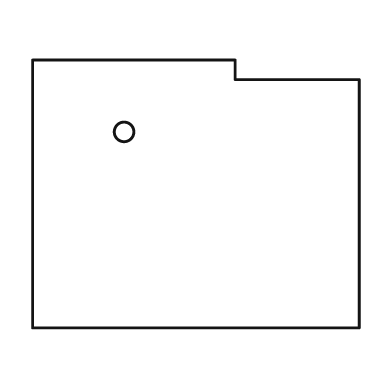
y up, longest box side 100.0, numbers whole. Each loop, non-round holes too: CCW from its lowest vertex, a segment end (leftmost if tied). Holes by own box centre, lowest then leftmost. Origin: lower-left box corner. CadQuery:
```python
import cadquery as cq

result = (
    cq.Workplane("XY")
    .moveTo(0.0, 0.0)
    .lineTo(100.0, 0.0)
    .lineTo(100.0, 76.0)
    .lineTo(62.0, 76.0)
    .lineTo(62.0, 82.0)
    .lineTo(0.0, 82.0)
    .close()
    .moveTo(28.0, 60.0)
    .circle(3.0)
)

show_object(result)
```